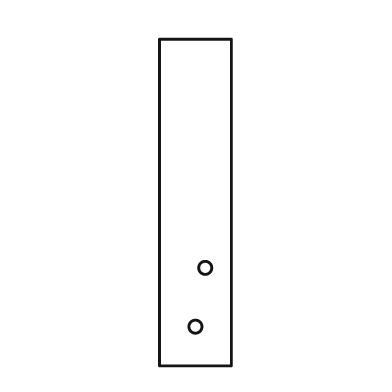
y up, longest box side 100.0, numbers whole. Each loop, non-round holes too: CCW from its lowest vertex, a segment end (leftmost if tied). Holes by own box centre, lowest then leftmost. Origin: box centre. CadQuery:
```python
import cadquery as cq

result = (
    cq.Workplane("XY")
    .moveTo(-11.0, -50.0)
    .lineTo(11.0, -50.0)
    .lineTo(11.0, 50.0)
    .lineTo(-11.0, 50.0)
    .close()
    .moveTo(0.0, -38.0)
    .circle(2.0)
    .moveTo(3.0, -20.0)
    .circle(2.0)
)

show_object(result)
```